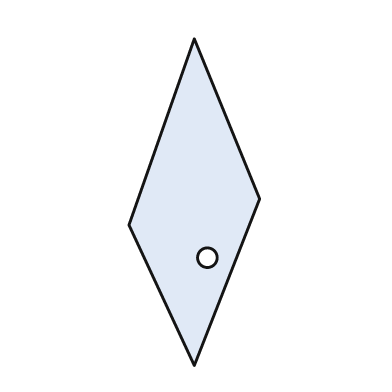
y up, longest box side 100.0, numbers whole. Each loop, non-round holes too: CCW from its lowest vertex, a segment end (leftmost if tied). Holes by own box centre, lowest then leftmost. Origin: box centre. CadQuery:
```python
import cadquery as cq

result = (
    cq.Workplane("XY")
    .moveTo(0.0, -50.0)
    .lineTo(20.0, 1.0)
    .lineTo(0.0, 50.0)
    .lineTo(-20.0, -7.0)
    .close()
    .moveTo(4.0, -17.0)
    .circle(3.0)
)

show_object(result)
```